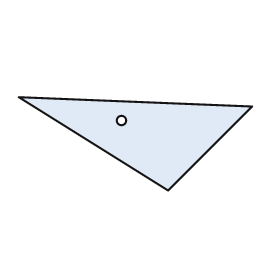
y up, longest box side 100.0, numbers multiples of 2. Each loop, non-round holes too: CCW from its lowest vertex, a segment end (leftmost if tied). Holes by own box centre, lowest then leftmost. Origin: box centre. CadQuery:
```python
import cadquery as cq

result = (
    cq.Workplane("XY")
    .moveTo(14.0, -20.0)
    .lineTo(50.0, 16.0)
    .lineTo(-50.0, 20.0)
    .close()
    .moveTo(-6.0, 10.0)
    .circle(2.0)
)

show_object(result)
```